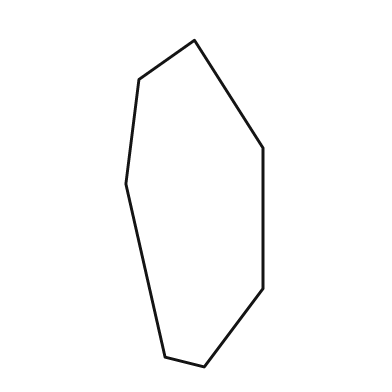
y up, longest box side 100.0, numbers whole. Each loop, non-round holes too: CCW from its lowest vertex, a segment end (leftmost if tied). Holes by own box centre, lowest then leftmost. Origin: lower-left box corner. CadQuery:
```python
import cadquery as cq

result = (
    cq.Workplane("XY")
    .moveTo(24.0, 0.0)
    .lineTo(42.0, 24.0)
    .lineTo(42.0, 67.0)
    .lineTo(21.0, 100.0)
    .lineTo(4.0, 88.0)
    .lineTo(0.0, 56.0)
    .lineTo(12.0, 3.0)
    .close()
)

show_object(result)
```